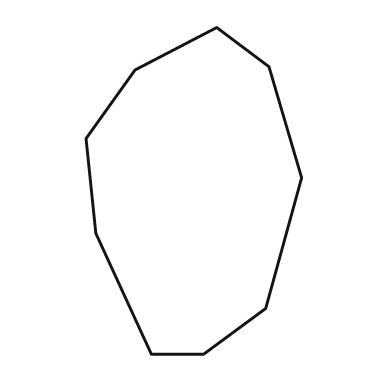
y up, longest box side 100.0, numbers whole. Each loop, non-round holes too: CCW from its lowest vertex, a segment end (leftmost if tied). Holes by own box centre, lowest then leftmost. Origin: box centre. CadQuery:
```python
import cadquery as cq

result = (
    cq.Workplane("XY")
    .moveTo(-13.0, -50.0)
    .lineTo(3.0, -50.0)
    .lineTo(22.0, -36.0)
    .lineTo(33.0, 4.0)
    .lineTo(23.0, 38.0)
    .lineTo(7.0, 50.0)
    .lineTo(-18.0, 37.0)
    .lineTo(-33.0, 16.0)
    .lineTo(-30.0, -13.0)
    .close()
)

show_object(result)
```